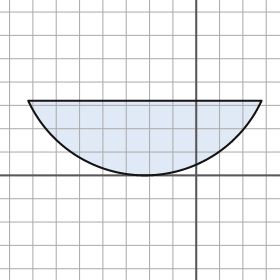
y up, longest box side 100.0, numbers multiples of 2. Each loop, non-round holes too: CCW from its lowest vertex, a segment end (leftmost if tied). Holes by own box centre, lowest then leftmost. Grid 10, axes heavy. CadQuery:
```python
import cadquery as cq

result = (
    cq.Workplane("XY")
    .moveTo(-72.0, 32.0)
    .threePointArc((-22.0, 0.0), (28.0, 32.0))
    .close()
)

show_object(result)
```